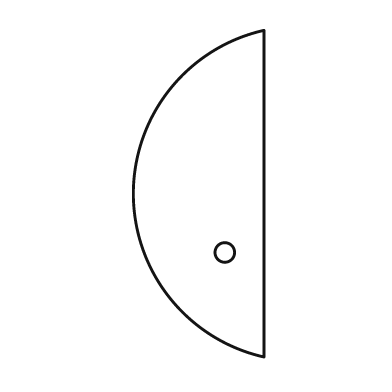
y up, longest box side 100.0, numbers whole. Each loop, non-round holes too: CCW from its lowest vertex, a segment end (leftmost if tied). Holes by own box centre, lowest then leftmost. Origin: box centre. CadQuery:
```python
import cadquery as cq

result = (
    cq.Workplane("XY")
    .moveTo(20.0, -50.0)
    .lineTo(20.0, 50.0)
    .threePointArc((-20.0, 0.0), (20.0, -50.0))
    .close()
    .moveTo(8.0, -18.0)
    .circle(3.0)
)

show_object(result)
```